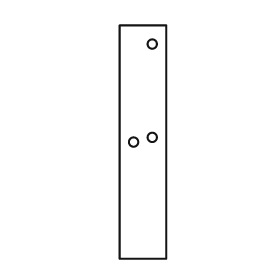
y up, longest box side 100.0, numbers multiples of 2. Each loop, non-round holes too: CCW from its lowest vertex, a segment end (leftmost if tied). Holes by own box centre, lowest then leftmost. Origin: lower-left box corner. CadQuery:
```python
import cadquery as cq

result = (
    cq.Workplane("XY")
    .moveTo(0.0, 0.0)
    .lineTo(20.0, 0.0)
    .lineTo(20.0, 100.0)
    .lineTo(0.0, 100.0)
    .close()
    .moveTo(6.0, 50.0)
    .circle(2.0)
    .moveTo(14.0, 52.0)
    .circle(2.0)
    .moveTo(14.0, 92.0)
    .circle(2.0)
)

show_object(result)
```